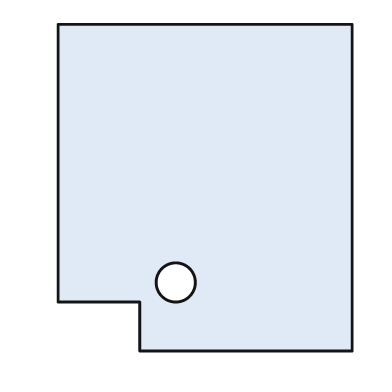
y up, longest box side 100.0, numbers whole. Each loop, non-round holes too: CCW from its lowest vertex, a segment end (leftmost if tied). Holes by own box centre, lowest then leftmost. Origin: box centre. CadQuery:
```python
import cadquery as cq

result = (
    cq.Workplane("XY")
    .moveTo(-20.0, -50.0)
    .lineTo(45.0, -50.0)
    .lineTo(45.0, 50.0)
    .lineTo(-45.0, 50.0)
    .lineTo(-45.0, -35.0)
    .lineTo(-20.0, -35.0)
    .close()
    .moveTo(-9.0, -29.0)
    .circle(6.0)
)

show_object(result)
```